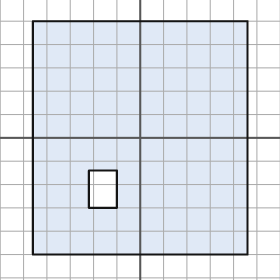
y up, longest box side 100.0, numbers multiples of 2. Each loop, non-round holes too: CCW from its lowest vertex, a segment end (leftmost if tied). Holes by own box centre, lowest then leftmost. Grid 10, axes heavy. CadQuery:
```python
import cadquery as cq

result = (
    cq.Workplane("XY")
    .moveTo(-46.0, -50.0)
    .lineTo(46.0, -50.0)
    .lineTo(46.0, 50.0)
    .lineTo(-46.0, 50.0)
    .close()
    .moveTo(-22.0, -30.0)
    .lineTo(-10.0, -30.0)
    .lineTo(-10.0, -14.0)
    .lineTo(-22.0, -14.0)
    .close()
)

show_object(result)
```